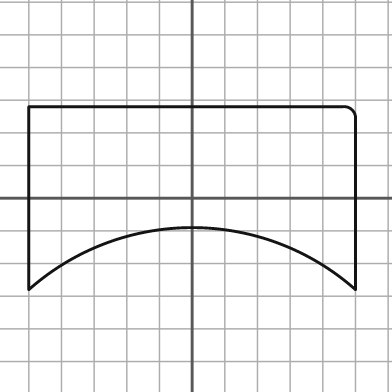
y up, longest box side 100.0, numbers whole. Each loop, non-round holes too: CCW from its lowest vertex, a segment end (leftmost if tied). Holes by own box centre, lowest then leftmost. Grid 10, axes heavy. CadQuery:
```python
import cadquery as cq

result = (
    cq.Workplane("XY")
    .moveTo(-50.0, -28.0)
    .threePointArc((0.0, -9.0), (50.0, -28.0))
    .lineTo(50.0, 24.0)
    .threePointArc((49.0, 27.0), (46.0, 28.0))
    .lineTo(-50.0, 28.0)
    .close()
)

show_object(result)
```